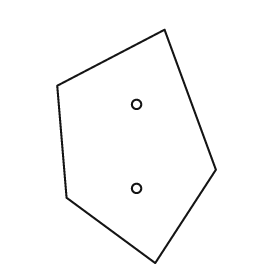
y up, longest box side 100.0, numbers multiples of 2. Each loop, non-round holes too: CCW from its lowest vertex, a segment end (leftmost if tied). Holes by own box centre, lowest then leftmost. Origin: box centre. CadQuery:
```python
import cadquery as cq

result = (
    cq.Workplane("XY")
    .moveTo(8.0, -50.0)
    .lineTo(34.0, -10.0)
    .lineTo(12.0, 50.0)
    .lineTo(-34.0, 26.0)
    .lineTo(-30.0, -22.0)
    .close()
    .moveTo(0.0, -18.0)
    .circle(2.0)
    .moveTo(0.0, 18.0)
    .circle(2.0)
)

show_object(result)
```